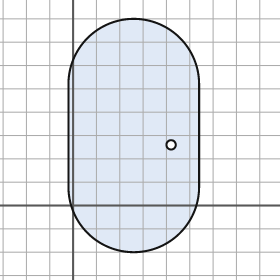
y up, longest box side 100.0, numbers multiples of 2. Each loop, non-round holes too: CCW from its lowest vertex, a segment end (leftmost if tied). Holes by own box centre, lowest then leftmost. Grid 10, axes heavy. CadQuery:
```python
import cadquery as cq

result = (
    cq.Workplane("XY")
    .moveTo(-2.0, 8.0)
    .threePointArc((26.0, -20.0), (54.0, 8.0))
    .lineTo(54.0, 52.0)
    .threePointArc((26.0, 80.0), (-2.0, 52.0))
    .close()
    .moveTo(42.0, 26.0)
    .circle(2.0)
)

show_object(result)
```